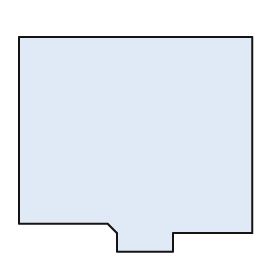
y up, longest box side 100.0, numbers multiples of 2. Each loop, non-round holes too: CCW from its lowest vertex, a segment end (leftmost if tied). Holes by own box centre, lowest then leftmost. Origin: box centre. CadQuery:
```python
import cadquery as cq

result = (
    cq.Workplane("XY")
    .moveTo(-8.0, -46.0)
    .lineTo(16.0, -46.0)
    .lineTo(16.0, -38.0)
    .lineTo(50.0, -38.0)
    .lineTo(50.0, 46.0)
    .lineTo(-50.0, 46.0)
    .lineTo(-50.0, -34.0)
    .lineTo(-12.0, -34.0)
    .lineTo(-8.0, -38.0)
    .close()
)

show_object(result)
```